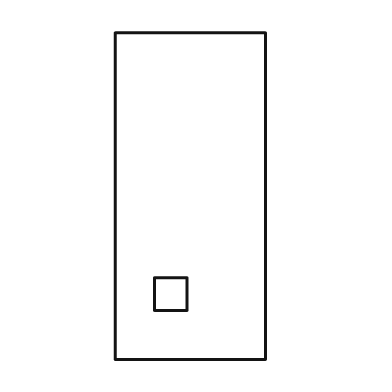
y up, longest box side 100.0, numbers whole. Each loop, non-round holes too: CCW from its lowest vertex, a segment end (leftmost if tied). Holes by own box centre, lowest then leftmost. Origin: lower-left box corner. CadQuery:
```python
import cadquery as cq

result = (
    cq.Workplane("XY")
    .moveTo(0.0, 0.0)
    .lineTo(46.0, 0.0)
    .lineTo(46.0, 100.0)
    .lineTo(0.0, 100.0)
    .close()
    .moveTo(12.0, 15.0)
    .lineTo(22.0, 15.0)
    .lineTo(22.0, 25.0)
    .lineTo(12.0, 25.0)
    .close()
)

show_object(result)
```